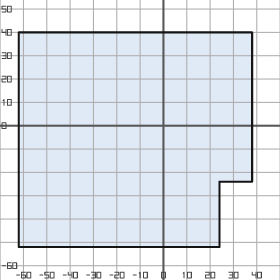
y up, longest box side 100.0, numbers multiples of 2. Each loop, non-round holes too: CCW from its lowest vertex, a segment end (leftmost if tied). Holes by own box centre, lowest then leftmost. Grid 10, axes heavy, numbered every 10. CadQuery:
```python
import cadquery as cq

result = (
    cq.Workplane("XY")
    .moveTo(-62.0, -52.0)
    .lineTo(24.0, -52.0)
    .lineTo(24.0, -24.0)
    .lineTo(38.0, -24.0)
    .lineTo(38.0, 40.0)
    .lineTo(-62.0, 40.0)
    .close()
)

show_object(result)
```